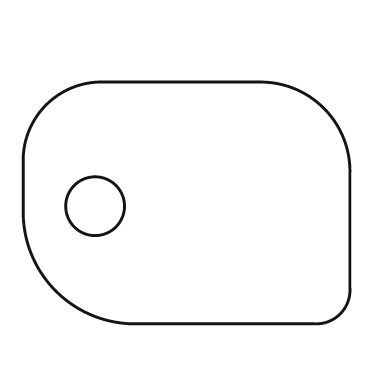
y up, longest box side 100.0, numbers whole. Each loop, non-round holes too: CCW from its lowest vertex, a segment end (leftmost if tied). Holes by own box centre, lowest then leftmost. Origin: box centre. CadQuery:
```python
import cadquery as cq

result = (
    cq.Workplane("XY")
    .moveTo(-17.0, -37.0)
    .lineTo(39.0, -37.0)
    .threePointArc((47.0, -34.0), (50.0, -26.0))
    .lineTo(50.0, 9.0)
    .threePointArc((42.0, 29.0), (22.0, 37.0))
    .lineTo(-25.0, 37.0)
    .threePointArc((-43.0, 30.0), (-50.0, 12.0))
    .lineTo(-50.0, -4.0)
    .threePointArc((-40.0, -27.0), (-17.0, -37.0))
    .close()
    .moveTo(-28.0, -1.0)
    .circle(9.0)
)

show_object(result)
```